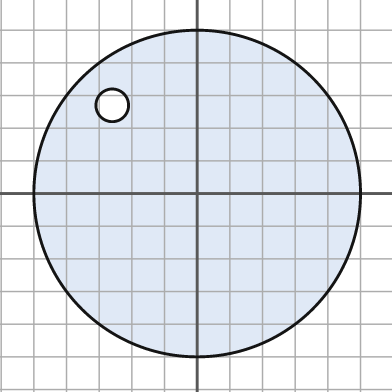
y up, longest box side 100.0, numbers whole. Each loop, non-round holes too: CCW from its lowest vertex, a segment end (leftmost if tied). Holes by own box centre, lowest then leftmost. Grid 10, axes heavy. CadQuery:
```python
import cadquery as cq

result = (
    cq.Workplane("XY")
    .moveTo(0.0, 0.0)
    .circle(50.0)
    .moveTo(-26.0, 27.0)
    .circle(5.0)
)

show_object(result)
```